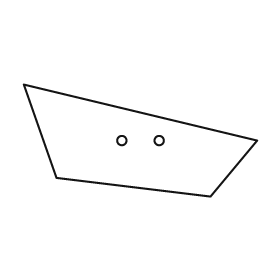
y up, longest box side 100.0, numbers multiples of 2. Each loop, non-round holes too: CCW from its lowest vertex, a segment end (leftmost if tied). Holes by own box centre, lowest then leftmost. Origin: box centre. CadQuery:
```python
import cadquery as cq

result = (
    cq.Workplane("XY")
    .moveTo(30.0, -24.0)
    .lineTo(50.0, 0.0)
    .lineTo(-50.0, 24.0)
    .lineTo(-36.0, -16.0)
    .close()
    .moveTo(-8.0, 0.0)
    .circle(2.0)
    .moveTo(8.0, 0.0)
    .circle(2.0)
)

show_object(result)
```